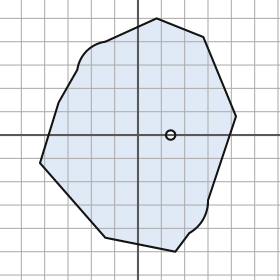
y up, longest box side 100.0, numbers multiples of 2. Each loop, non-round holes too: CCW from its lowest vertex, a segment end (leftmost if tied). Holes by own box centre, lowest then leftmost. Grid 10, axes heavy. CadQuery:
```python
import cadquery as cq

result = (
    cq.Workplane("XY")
    .moveTo(16.0, -50.0)
    .lineTo(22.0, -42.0)
    .threePointArc((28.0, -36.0), (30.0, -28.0))
    .lineTo(42.0, 8.0)
    .lineTo(28.0, 42.0)
    .lineTo(8.0, 50.0)
    .lineTo(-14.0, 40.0)
    .threePointArc((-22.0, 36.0), (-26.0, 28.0))
    .lineTo(-34.0, 14.0)
    .lineTo(-42.0, -12.0)
    .lineTo(-14.0, -44.0)
    .close()
    .moveTo(14.0, 0.0)
    .circle(2.0)
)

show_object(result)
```